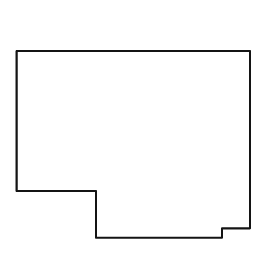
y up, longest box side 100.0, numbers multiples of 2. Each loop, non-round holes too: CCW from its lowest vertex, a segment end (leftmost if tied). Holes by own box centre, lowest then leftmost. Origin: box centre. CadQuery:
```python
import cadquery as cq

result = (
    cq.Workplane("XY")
    .moveTo(-16.0, -40.0)
    .lineTo(38.0, -40.0)
    .lineTo(38.0, -36.0)
    .lineTo(50.0, -36.0)
    .lineTo(50.0, 40.0)
    .lineTo(-50.0, 40.0)
    .lineTo(-50.0, -20.0)
    .lineTo(-16.0, -20.0)
    .close()
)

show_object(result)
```